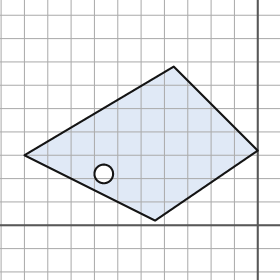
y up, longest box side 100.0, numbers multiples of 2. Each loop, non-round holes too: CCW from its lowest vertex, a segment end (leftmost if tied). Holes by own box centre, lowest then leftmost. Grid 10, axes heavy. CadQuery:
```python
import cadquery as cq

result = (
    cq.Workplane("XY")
    .moveTo(-44.0, 2.0)
    .lineTo(0.0, 32.0)
    .lineTo(-36.0, 68.0)
    .lineTo(-100.0, 30.0)
    .close()
    .moveTo(-66.0, 22.0)
    .circle(4.0)
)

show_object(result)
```